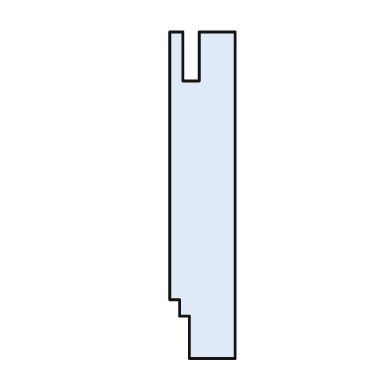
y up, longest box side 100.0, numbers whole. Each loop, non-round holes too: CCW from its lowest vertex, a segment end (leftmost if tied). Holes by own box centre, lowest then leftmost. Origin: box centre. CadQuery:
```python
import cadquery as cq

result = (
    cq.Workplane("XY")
    .moveTo(-4.0, -50.0)
    .lineTo(10.0, -50.0)
    .lineTo(10.0, 50.0)
    .lineTo(-1.0, 50.0)
    .lineTo(-1.0, 35.0)
    .lineTo(-6.0, 35.0)
    .lineTo(-6.0, 50.0)
    .lineTo(-10.0, 50.0)
    .lineTo(-10.0, -32.0)
    .lineTo(-7.0, -32.0)
    .lineTo(-7.0, -37.0)
    .lineTo(-4.0, -37.0)
    .close()
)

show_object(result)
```